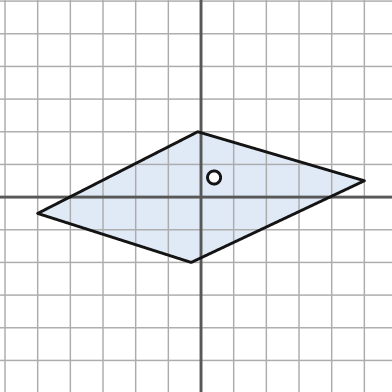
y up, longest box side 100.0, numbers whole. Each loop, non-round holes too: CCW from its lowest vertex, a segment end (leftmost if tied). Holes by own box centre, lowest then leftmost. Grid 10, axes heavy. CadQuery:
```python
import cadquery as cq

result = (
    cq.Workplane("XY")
    .moveTo(-3.0, -20.0)
    .lineTo(50.0, 5.0)
    .lineTo(-1.0, 20.0)
    .lineTo(-50.0, -5.0)
    .close()
    .moveTo(4.0, 6.0)
    .circle(2.0)
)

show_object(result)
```